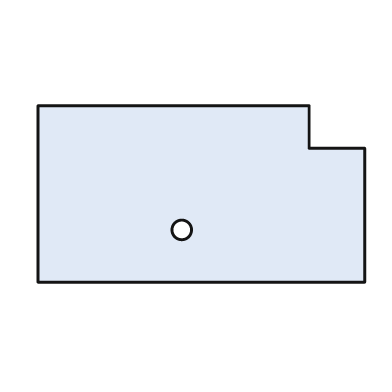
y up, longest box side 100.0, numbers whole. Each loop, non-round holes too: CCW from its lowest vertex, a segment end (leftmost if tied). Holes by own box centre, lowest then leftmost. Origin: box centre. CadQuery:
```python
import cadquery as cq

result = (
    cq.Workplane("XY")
    .moveTo(-50.0, -27.0)
    .lineTo(50.0, -27.0)
    .lineTo(50.0, 14.0)
    .lineTo(33.0, 14.0)
    .lineTo(33.0, 27.0)
    .lineTo(-50.0, 27.0)
    .close()
    .moveTo(-6.0, -11.0)
    .circle(3.0)
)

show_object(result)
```